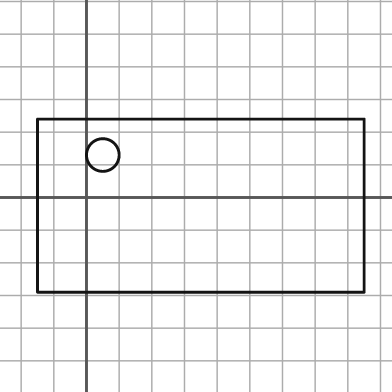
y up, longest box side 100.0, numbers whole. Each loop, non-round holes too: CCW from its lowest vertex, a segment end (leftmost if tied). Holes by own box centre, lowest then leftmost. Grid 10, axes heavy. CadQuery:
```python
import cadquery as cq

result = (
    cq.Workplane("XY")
    .moveTo(-15.0, -29.0)
    .lineTo(85.0, -29.0)
    .lineTo(85.0, 24.0)
    .lineTo(-15.0, 24.0)
    .close()
    .moveTo(5.0, 13.0)
    .circle(5.0)
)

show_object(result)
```